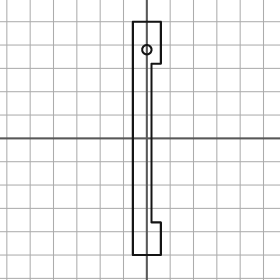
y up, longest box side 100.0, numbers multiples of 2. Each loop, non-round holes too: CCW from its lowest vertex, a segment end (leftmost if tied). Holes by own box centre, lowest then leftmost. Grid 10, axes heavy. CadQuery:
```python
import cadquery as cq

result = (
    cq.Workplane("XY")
    .moveTo(-6.0, -50.0)
    .lineTo(6.0, -50.0)
    .lineTo(6.0, -36.0)
    .lineTo(2.0, -36.0)
    .lineTo(2.0, 32.0)
    .lineTo(6.0, 32.0)
    .lineTo(6.0, 50.0)
    .lineTo(-6.0, 50.0)
    .close()
    .moveTo(0.0, 38.0)
    .circle(2.0)
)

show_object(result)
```